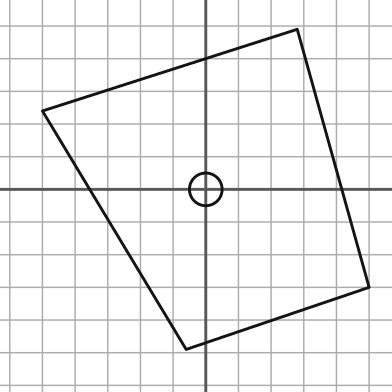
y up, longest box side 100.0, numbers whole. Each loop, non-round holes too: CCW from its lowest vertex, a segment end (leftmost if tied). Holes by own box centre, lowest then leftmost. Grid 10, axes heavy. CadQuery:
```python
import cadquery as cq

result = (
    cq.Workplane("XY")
    .moveTo(-6.0, -49.0)
    .lineTo(50.0, -30.0)
    .lineTo(28.0, 49.0)
    .lineTo(-50.0, 24.0)
    .close()
    .moveTo(0.0, 0.0)
    .circle(5.0)
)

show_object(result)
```